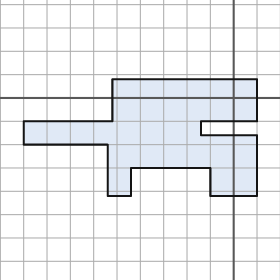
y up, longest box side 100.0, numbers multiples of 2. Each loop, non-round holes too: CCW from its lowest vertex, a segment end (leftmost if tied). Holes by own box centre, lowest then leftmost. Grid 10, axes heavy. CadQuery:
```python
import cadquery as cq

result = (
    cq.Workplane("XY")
    .moveTo(-54.0, -42.0)
    .lineTo(-44.0, -42.0)
    .lineTo(-44.0, -30.0)
    .lineTo(-10.0, -30.0)
    .lineTo(-10.0, -42.0)
    .lineTo(10.0, -42.0)
    .lineTo(10.0, -16.0)
    .lineTo(-14.0, -16.0)
    .lineTo(-14.0, -10.0)
    .lineTo(10.0, -10.0)
    .lineTo(10.0, 8.0)
    .lineTo(-52.0, 8.0)
    .lineTo(-52.0, -10.0)
    .lineTo(-90.0, -10.0)
    .lineTo(-90.0, -20.0)
    .lineTo(-54.0, -20.0)
    .close()
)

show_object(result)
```